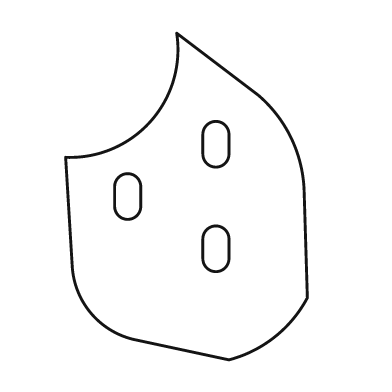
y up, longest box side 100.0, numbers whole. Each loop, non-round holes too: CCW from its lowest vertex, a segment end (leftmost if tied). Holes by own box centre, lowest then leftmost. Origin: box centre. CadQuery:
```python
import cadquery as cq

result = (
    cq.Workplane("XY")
    .moveTo(13.0, -50.0)
    .threePointArc((27.0, -43.0), (37.0, -31.0))
    .lineTo(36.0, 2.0)
    .threePointArc((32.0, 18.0), (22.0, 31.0))
    .lineTo(-3.0, 50.0)
    .threePointArc((-11.0, 23.0), (-37.0, 12.0))
    .lineTo(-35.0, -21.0)
    .threePointArc((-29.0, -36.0), (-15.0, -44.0))
    .close()
    .moveTo(5.0, -19.0)
    .threePointArc((9.0, -23.0), (13.0, -19.0))
    .lineTo(13.0, -13.0)
    .threePointArc((9.0, -9.0), (5.0, -13.0))
    .close()
    .moveTo(-22.0, -3.0)
    .threePointArc((-18.0, -7.0), (-14.0, -3.0))
    .lineTo(-14.0, 3.0)
    .threePointArc((-18.0, 7.0), (-22.0, 3.0))
    .close()
    .moveTo(5.0, 13.0)
    .threePointArc((9.0, 9.0), (13.0, 13.0))
    .lineTo(13.0, 19.0)
    .threePointArc((9.0, 23.0), (5.0, 19.0))
    .close()
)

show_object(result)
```